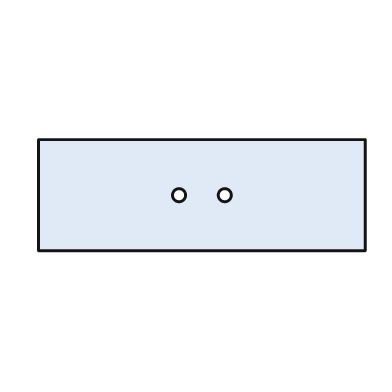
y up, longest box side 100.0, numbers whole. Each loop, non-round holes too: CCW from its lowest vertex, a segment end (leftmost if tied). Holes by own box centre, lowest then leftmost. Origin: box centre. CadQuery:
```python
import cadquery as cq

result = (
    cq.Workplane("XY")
    .moveTo(-50.0, -17.0)
    .lineTo(50.0, -17.0)
    .lineTo(50.0, 17.0)
    .lineTo(-50.0, 17.0)
    .close()
    .moveTo(-7.0, 0.0)
    .circle(2.0)
    .moveTo(7.0, 0.0)
    .circle(2.0)
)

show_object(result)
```